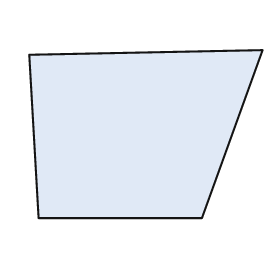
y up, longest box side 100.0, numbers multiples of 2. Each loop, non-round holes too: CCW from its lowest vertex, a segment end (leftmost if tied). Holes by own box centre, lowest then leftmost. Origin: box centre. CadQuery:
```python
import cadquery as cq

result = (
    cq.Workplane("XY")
    .moveTo(-46.0, -36.0)
    .lineTo(24.0, -36.0)
    .lineTo(50.0, 36.0)
    .lineTo(-50.0, 34.0)
    .close()
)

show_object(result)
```